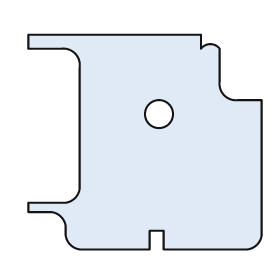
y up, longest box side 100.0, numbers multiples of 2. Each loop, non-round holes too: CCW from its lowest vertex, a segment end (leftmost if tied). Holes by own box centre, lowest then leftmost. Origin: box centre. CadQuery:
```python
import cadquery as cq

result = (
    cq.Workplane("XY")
    .moveTo(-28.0, -46.0)
    .lineTo(2.0, -46.0)
    .lineTo(2.0, -38.0)
    .lineTo(8.0, -38.0)
    .lineTo(8.0, -46.0)
    .lineTo(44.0, -46.0)
    .threePointArc((48.0, -44.0), (50.0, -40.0))
    .lineTo(50.0, 18.0)
    .lineTo(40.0, 18.0)
    .threePointArc((34.0, 20.0), (32.0, 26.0))
    .lineTo(32.0, 40.0)
    .threePointArc((28.0, 42.0), (24.0, 40.0))
    .lineTo(24.0, 46.0)
    .lineTo(-50.0, 46.0)
    .lineTo(-50.0, 40.0)
    .lineTo(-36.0, 40.0)
    .threePointArc((-30.0, 38.0), (-28.0, 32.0))
    .lineTo(-28.0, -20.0)
    .threePointArc((-30.0, -24.0), (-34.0, -26.0))
    .lineTo(-50.0, -26.0)
    .lineTo(-50.0, -30.0)
    .lineTo(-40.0, -30.0)
    .threePointArc((-36.0, -32.0), (-34.0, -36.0))
    .lineTo(-34.0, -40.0)
    .threePointArc((-32.0, -44.0), (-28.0, -46.0))
    .close()
    .moveTo(6.0, 12.0)
    .circle(6.0)
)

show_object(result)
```